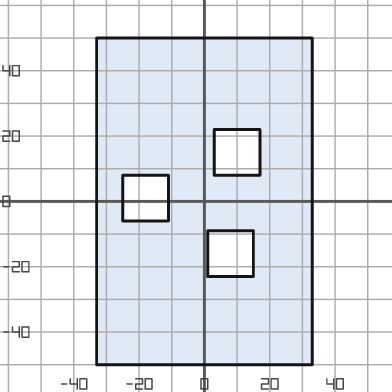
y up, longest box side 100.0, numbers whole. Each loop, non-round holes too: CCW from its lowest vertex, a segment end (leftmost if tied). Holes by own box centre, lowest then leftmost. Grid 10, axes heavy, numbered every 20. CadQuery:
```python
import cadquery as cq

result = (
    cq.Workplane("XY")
    .moveTo(-33.0, -50.0)
    .lineTo(33.0, -50.0)
    .lineTo(33.0, 50.0)
    .lineTo(-33.0, 50.0)
    .close()
    .moveTo(1.0, -23.0)
    .lineTo(15.0, -23.0)
    .lineTo(15.0, -9.0)
    .lineTo(1.0, -9.0)
    .close()
    .moveTo(-25.0, -6.0)
    .lineTo(-11.0, -6.0)
    .lineTo(-11.0, 8.0)
    .lineTo(-25.0, 8.0)
    .close()
    .moveTo(3.0, 8.0)
    .lineTo(17.0, 8.0)
    .lineTo(17.0, 22.0)
    .lineTo(3.0, 22.0)
    .close()
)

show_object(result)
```